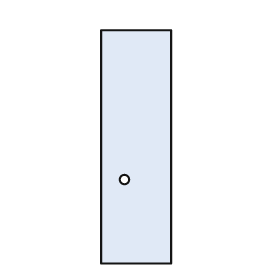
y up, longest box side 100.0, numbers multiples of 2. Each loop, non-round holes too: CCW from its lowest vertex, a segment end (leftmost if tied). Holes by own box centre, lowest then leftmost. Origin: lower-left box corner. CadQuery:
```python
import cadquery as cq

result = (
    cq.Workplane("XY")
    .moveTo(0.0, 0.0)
    .lineTo(30.0, 0.0)
    .lineTo(30.0, 100.0)
    .lineTo(0.0, 100.0)
    .close()
    .moveTo(10.0, 36.0)
    .circle(2.0)
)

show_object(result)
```